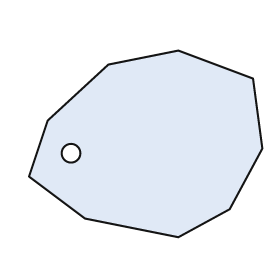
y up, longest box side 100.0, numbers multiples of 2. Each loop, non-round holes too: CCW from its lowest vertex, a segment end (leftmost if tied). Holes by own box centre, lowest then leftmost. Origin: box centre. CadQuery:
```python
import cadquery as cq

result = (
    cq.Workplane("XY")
    .moveTo(14.0, -40.0)
    .lineTo(36.0, -28.0)
    .lineTo(50.0, -2.0)
    .lineTo(46.0, 28.0)
    .lineTo(14.0, 40.0)
    .lineTo(-16.0, 34.0)
    .lineTo(-42.0, 10.0)
    .lineTo(-50.0, -14.0)
    .lineTo(-26.0, -32.0)
    .close()
    .moveTo(-32.0, -4.0)
    .circle(4.0)
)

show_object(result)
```